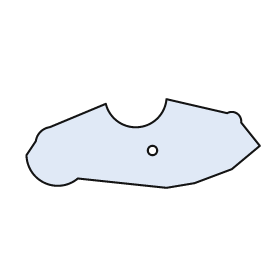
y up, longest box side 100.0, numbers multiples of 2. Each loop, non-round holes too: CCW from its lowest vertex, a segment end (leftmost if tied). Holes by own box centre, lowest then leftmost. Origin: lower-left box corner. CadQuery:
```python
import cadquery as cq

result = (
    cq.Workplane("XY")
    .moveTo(60.0, 0.0)
    .lineTo(72.0, 2.0)
    .lineTo(88.0, 8.0)
    .lineTo(100.0, 18.0)
    .lineTo(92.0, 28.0)
    .threePointArc((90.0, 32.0), (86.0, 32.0))
    .lineTo(60.0, 38.0)
    .threePointArc((48.0, 26.0), (34.0, 36.0))
    .lineTo(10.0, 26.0)
    .threePointArc((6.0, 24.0), (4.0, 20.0))
    .lineTo(0.0, 14.0)
    .threePointArc((8.0, 2.0), (22.0, 4.0))
    .close()
    .moveTo(54.0, 16.0)
    .circle(2.0)
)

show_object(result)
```